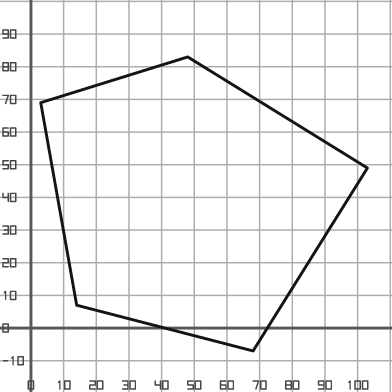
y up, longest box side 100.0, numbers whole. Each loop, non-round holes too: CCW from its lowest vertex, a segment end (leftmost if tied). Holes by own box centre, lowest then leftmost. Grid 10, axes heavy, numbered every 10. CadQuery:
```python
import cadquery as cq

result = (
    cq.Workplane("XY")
    .moveTo(68.0, -7.0)
    .lineTo(103.0, 49.0)
    .lineTo(48.0, 83.0)
    .lineTo(3.0, 69.0)
    .lineTo(14.0, 7.0)
    .close()
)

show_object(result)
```